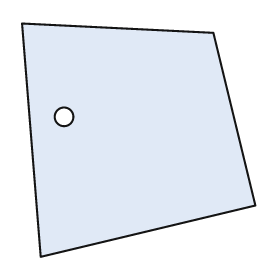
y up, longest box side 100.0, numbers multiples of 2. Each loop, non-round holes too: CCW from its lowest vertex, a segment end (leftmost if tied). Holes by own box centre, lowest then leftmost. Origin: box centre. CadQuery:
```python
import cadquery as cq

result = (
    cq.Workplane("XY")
    .moveTo(-42.0, -50.0)
    .lineTo(50.0, -28.0)
    .lineTo(32.0, 46.0)
    .lineTo(-50.0, 50.0)
    .close()
    .moveTo(-32.0, 10.0)
    .circle(4.0)
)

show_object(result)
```